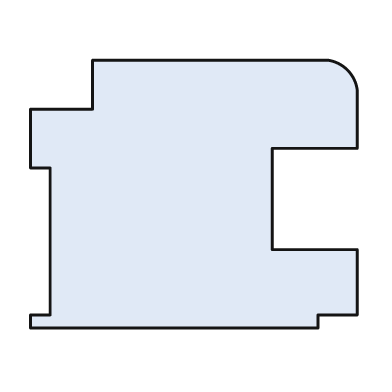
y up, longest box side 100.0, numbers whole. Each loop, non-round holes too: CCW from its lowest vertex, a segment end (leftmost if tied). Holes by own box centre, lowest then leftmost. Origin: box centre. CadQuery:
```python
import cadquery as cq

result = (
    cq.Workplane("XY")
    .moveTo(-50.0, -41.0)
    .lineTo(38.0, -41.0)
    .lineTo(38.0, -37.0)
    .lineTo(50.0, -37.0)
    .lineTo(50.0, -17.0)
    .lineTo(24.0, -17.0)
    .lineTo(24.0, 14.0)
    .lineTo(50.0, 14.0)
    .lineTo(50.0, 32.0)
    .threePointArc((47.0, 38.0), (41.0, 41.0))
    .lineTo(-31.0, 41.0)
    .lineTo(-31.0, 26.0)
    .lineTo(-50.0, 26.0)
    .lineTo(-50.0, 8.0)
    .lineTo(-44.0, 8.0)
    .lineTo(-44.0, -37.0)
    .lineTo(-50.0, -37.0)
    .close()
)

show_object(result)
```